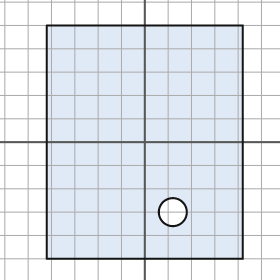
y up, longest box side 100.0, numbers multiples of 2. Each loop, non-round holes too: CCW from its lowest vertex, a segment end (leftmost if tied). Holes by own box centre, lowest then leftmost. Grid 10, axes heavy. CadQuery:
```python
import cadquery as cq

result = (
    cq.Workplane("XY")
    .moveTo(-42.0, -50.0)
    .lineTo(42.0, -50.0)
    .lineTo(42.0, 50.0)
    .lineTo(-42.0, 50.0)
    .close()
    .moveTo(12.0, -30.0)
    .circle(6.0)
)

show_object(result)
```